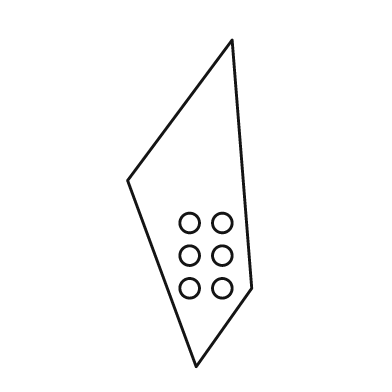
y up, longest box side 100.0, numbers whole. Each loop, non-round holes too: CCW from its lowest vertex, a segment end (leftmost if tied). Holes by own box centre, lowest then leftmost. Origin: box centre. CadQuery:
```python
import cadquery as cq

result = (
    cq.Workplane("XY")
    .moveTo(2.0, -50.0)
    .lineTo(19.0, -26.0)
    .lineTo(13.0, 50.0)
    .lineTo(-19.0, 7.0)
    .close()
    .moveTo(0.0, -26.0)
    .circle(3.0)
    .moveTo(10.0, -26.0)
    .circle(3.0)
    .moveTo(0.0, -16.0)
    .circle(3.0)
    .moveTo(10.0, -16.0)
    .circle(3.0)
    .moveTo(0.0, -6.0)
    .circle(3.0)
    .moveTo(10.0, -6.0)
    .circle(3.0)
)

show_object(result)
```